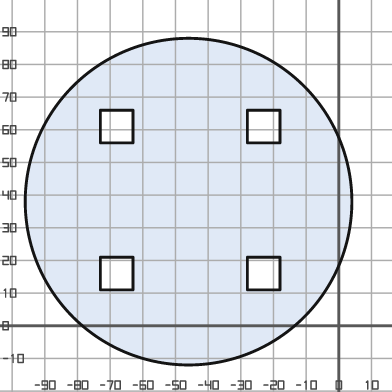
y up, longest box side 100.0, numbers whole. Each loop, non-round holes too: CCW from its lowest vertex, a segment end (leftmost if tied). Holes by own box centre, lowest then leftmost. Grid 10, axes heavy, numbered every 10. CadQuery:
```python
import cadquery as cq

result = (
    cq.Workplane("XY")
    .moveTo(-46.0, 38.0)
    .circle(50.0)
    .moveTo(-73.0, 11.0)
    .lineTo(-63.0, 11.0)
    .lineTo(-63.0, 21.0)
    .lineTo(-73.0, 21.0)
    .close()
    .moveTo(-28.0, 11.0)
    .lineTo(-18.0, 11.0)
    .lineTo(-18.0, 21.0)
    .lineTo(-28.0, 21.0)
    .close()
    .moveTo(-73.0, 56.0)
    .lineTo(-63.0, 56.0)
    .lineTo(-63.0, 66.0)
    .lineTo(-73.0, 66.0)
    .close()
    .moveTo(-28.0, 56.0)
    .lineTo(-18.0, 56.0)
    .lineTo(-18.0, 66.0)
    .lineTo(-28.0, 66.0)
    .close()
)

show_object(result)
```